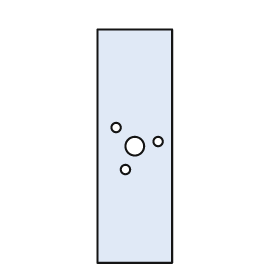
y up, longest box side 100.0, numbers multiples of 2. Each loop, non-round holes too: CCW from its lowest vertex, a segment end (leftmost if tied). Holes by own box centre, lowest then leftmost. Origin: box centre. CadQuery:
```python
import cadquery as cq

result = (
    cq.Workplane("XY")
    .moveTo(-16.0, -50.0)
    .lineTo(16.0, -50.0)
    .lineTo(16.0, 50.0)
    .lineTo(-16.0, 50.0)
    .close()
    .moveTo(-4.0, -10.0)
    .circle(2.0)
    .moveTo(0.0, 0.0)
    .circle(4.0)
    .moveTo(10.0, 2.0)
    .circle(2.0)
    .moveTo(-8.0, 8.0)
    .circle(2.0)
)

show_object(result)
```